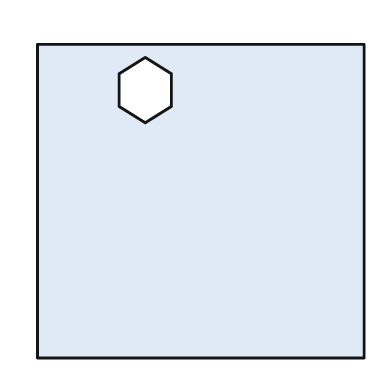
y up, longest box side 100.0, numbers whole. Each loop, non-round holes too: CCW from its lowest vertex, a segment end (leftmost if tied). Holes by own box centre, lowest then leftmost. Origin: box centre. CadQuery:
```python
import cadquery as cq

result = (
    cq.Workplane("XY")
    .moveTo(-50.0, -48.0)
    .lineTo(50.0, -48.0)
    .lineTo(50.0, 48.0)
    .lineTo(-50.0, 48.0)
    .close()
    .moveTo(-17.0, 24.0)
    .lineTo(-9.0, 29.0)
    .lineTo(-9.0, 39.0)
    .lineTo(-17.0, 44.0)
    .lineTo(-25.0, 39.0)
    .lineTo(-25.0, 29.0)
    .close()
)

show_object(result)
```